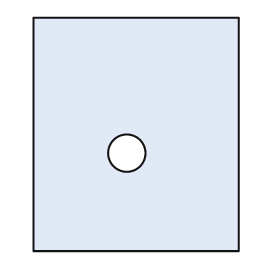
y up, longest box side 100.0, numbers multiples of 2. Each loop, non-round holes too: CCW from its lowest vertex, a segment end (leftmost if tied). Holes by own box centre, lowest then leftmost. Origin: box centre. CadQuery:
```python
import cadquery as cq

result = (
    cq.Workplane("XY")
    .moveTo(-44.0, -50.0)
    .lineTo(44.0, -50.0)
    .lineTo(44.0, 50.0)
    .lineTo(-44.0, 50.0)
    .close()
    .moveTo(-4.0, -8.0)
    .circle(8.0)
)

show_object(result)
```